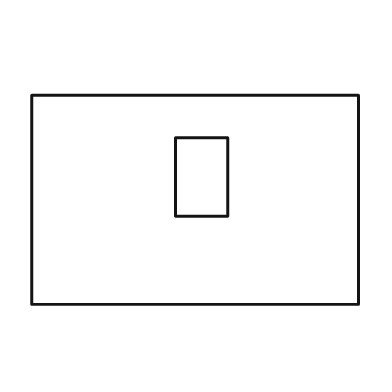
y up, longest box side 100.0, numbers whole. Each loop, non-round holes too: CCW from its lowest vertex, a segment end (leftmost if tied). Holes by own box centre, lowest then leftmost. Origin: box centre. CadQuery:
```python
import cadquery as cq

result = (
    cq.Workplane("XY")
    .moveTo(-50.0, -32.0)
    .lineTo(50.0, -32.0)
    .lineTo(50.0, 32.0)
    .lineTo(-50.0, 32.0)
    .close()
    .moveTo(-6.0, -5.0)
    .lineTo(10.0, -5.0)
    .lineTo(10.0, 19.0)
    .lineTo(-6.0, 19.0)
    .close()
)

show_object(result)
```